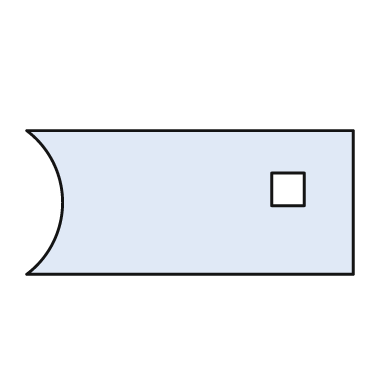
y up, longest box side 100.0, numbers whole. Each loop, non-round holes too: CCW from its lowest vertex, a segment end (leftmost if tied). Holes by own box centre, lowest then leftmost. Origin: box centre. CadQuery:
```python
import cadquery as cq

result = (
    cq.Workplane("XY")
    .moveTo(-50.0, -22.0)
    .lineTo(50.0, -22.0)
    .lineTo(50.0, 22.0)
    .lineTo(-50.0, 22.0)
    .threePointArc((-39.0, 0.0), (-50.0, -22.0))
    .close()
    .moveTo(25.0, -1.0)
    .lineTo(35.0, -1.0)
    .lineTo(35.0, 9.0)
    .lineTo(25.0, 9.0)
    .close()
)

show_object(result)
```